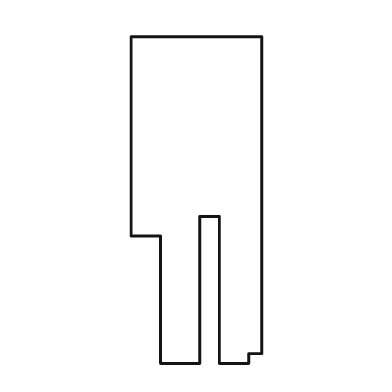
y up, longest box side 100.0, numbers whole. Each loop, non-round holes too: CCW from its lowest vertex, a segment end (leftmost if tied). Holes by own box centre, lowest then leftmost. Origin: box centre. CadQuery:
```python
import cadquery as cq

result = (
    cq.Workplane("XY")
    .moveTo(-11.0, -50.0)
    .lineTo(1.0, -50.0)
    .lineTo(1.0, -5.0)
    .lineTo(7.0, -5.0)
    .lineTo(7.0, -50.0)
    .lineTo(16.0, -50.0)
    .lineTo(16.0, -47.0)
    .lineTo(20.0, -47.0)
    .lineTo(20.0, 50.0)
    .lineTo(-20.0, 50.0)
    .lineTo(-20.0, -11.0)
    .lineTo(-11.0, -11.0)
    .close()
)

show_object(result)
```